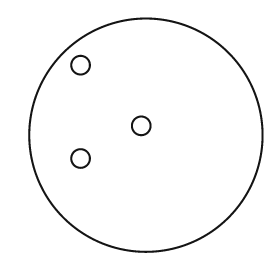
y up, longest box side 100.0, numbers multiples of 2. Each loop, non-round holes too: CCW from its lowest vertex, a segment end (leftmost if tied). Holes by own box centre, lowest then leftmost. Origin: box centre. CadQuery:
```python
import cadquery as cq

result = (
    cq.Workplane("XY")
    .moveTo(0.0, 0.0)
    .circle(50.0)
    .moveTo(-28.0, -10.0)
    .circle(4.0)
    .moveTo(-2.0, 4.0)
    .circle(4.0)
    .moveTo(-28.0, 30.0)
    .circle(4.0)
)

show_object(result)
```